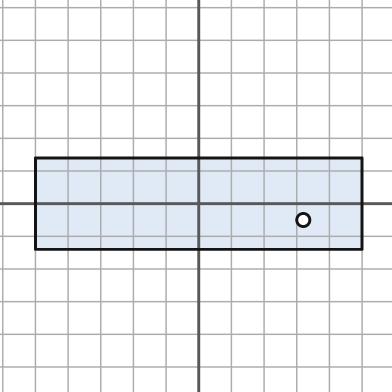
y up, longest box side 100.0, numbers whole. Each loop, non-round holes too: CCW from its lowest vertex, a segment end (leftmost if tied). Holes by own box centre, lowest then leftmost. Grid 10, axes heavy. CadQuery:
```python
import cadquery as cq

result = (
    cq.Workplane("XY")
    .moveTo(-50.0, -14.0)
    .lineTo(50.0, -14.0)
    .lineTo(50.0, 14.0)
    .lineTo(-50.0, 14.0)
    .close()
    .moveTo(32.0, -5.0)
    .circle(2.0)
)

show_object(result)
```